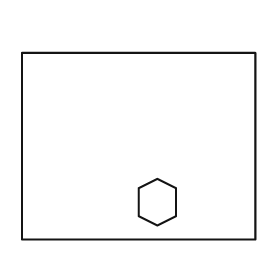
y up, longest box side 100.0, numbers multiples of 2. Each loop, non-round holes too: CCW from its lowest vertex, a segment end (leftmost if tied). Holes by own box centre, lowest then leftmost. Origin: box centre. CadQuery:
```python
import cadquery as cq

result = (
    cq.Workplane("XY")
    .moveTo(-50.0, -40.0)
    .lineTo(50.0, -40.0)
    .lineTo(50.0, 40.0)
    .lineTo(-50.0, 40.0)
    .close()
    .moveTo(8.0, -34.0)
    .lineTo(16.0, -30.0)
    .lineTo(16.0, -18.0)
    .lineTo(8.0, -14.0)
    .lineTo(0.0, -18.0)
    .lineTo(0.0, -30.0)
    .close()
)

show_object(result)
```